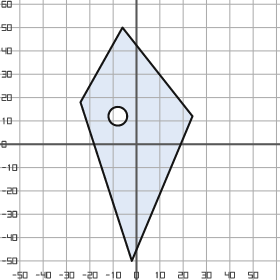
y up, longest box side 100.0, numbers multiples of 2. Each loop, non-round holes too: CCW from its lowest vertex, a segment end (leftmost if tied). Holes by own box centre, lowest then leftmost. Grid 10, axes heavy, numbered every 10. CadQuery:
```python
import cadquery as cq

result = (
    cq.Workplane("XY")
    .moveTo(-2.0, -50.0)
    .lineTo(24.0, 12.0)
    .lineTo(-6.0, 50.0)
    .lineTo(-24.0, 18.0)
    .close()
    .moveTo(-8.0, 12.0)
    .circle(4.0)
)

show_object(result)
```